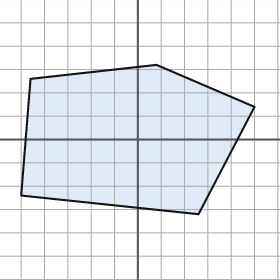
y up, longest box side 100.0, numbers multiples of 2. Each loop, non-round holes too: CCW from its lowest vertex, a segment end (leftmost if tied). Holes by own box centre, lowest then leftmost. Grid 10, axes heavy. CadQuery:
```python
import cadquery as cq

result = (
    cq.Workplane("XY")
    .moveTo(26.0, -32.0)
    .lineTo(50.0, 14.0)
    .lineTo(8.0, 32.0)
    .lineTo(-46.0, 26.0)
    .lineTo(-50.0, -24.0)
    .close()
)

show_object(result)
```